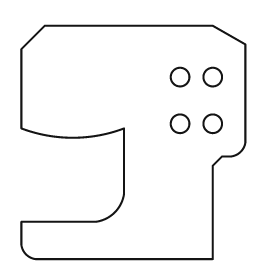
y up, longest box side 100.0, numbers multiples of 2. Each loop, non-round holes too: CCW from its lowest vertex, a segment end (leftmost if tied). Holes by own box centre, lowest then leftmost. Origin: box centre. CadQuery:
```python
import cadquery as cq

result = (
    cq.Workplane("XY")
    .moveTo(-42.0, -50.0)
    .lineTo(34.0, -50.0)
    .lineTo(34.0, -10.0)
    .lineTo(38.0, -6.0)
    .lineTo(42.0, -6.0)
    .threePointArc((46.0, -4.0), (48.0, 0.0))
    .lineTo(48.0, 42.0)
    .lineTo(34.0, 50.0)
    .lineTo(-38.0, 50.0)
    .lineTo(-48.0, 40.0)
    .lineTo(-48.0, 6.0)
    .threePointArc((-26.0, 2.0), (-4.0, 6.0))
    .lineTo(-4.0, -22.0)
    .threePointArc((-8.0, -30.0), (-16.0, -34.0))
    .lineTo(-48.0, -34.0)
    .lineTo(-48.0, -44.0)
    .threePointArc((-46.0, -48.0), (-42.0, -50.0))
    .close()
    .moveTo(20.0, 8.0)
    .circle(4.0)
    .moveTo(34.0, 8.0)
    .circle(4.0)
    .moveTo(20.0, 28.0)
    .circle(4.0)
    .moveTo(34.0, 28.0)
    .circle(4.0)
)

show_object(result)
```